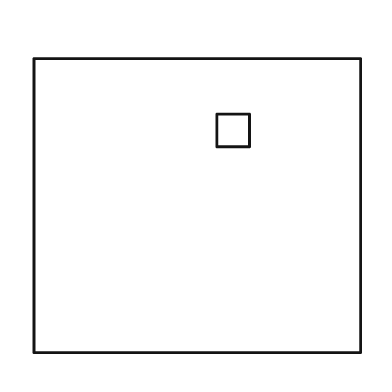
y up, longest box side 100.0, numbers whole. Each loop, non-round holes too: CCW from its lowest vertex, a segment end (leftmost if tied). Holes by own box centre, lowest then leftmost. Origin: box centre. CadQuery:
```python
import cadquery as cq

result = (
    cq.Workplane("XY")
    .moveTo(-50.0, -45.0)
    .lineTo(50.0, -45.0)
    .lineTo(50.0, 45.0)
    .lineTo(-50.0, 45.0)
    .close()
    .moveTo(6.0, 18.0)
    .lineTo(16.0, 18.0)
    .lineTo(16.0, 28.0)
    .lineTo(6.0, 28.0)
    .close()
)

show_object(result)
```